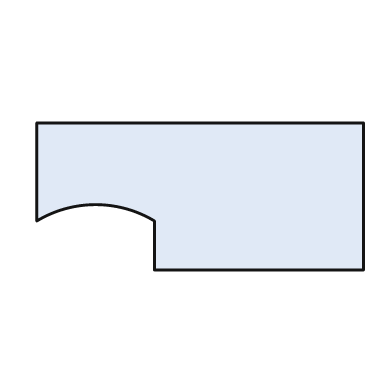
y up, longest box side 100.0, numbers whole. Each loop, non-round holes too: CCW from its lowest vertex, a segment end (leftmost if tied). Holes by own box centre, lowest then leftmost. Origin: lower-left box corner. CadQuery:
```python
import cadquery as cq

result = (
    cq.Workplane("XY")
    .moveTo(36.0, 0.0)
    .lineTo(100.0, 0.0)
    .lineTo(100.0, 45.0)
    .lineTo(0.0, 45.0)
    .lineTo(0.0, 15.0)
    .threePointArc((18.0, 20.0), (36.0, 15.0))
    .close()
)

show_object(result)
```